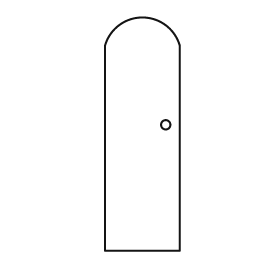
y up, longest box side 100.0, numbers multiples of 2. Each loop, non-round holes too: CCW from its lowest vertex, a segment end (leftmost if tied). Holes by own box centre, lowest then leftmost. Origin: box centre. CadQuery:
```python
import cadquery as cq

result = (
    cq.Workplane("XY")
    .moveTo(-16.0, -50.0)
    .lineTo(16.0, -50.0)
    .lineTo(16.0, 38.0)
    .threePointArc((0.0, 50.0), (-16.0, 38.0))
    .close()
    .moveTo(10.0, 4.0)
    .circle(2.0)
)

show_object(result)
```